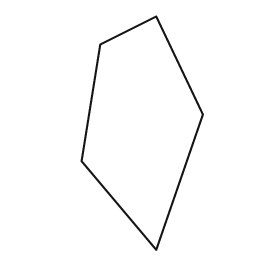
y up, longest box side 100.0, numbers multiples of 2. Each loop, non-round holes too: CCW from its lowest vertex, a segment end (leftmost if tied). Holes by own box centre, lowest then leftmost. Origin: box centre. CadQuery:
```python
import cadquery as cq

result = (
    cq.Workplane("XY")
    .moveTo(6.0, -50.0)
    .lineTo(26.0, 8.0)
    .lineTo(6.0, 50.0)
    .lineTo(-18.0, 38.0)
    .lineTo(-26.0, -12.0)
    .close()
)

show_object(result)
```